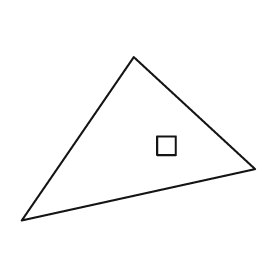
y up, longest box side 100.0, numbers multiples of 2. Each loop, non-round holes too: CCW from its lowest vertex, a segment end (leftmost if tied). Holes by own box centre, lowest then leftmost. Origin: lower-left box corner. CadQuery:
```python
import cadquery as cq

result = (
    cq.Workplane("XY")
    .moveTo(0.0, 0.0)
    .lineTo(100.0, 22.0)
    .lineTo(48.0, 70.0)
    .close()
    .moveTo(58.0, 28.0)
    .lineTo(66.0, 28.0)
    .lineTo(66.0, 36.0)
    .lineTo(58.0, 36.0)
    .close()
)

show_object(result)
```